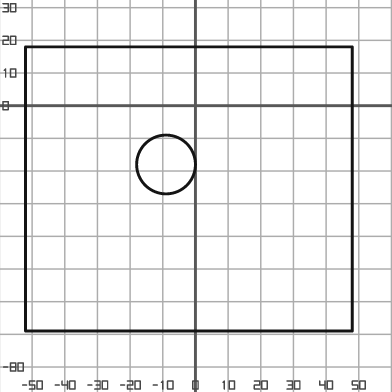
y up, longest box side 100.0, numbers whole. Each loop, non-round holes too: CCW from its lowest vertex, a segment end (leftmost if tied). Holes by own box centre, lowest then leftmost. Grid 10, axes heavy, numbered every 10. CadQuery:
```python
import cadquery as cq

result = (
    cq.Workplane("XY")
    .moveTo(-52.0, -69.0)
    .lineTo(48.0, -69.0)
    .lineTo(48.0, 18.0)
    .lineTo(-52.0, 18.0)
    .close()
    .moveTo(-9.0, -18.0)
    .circle(9.0)
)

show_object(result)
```